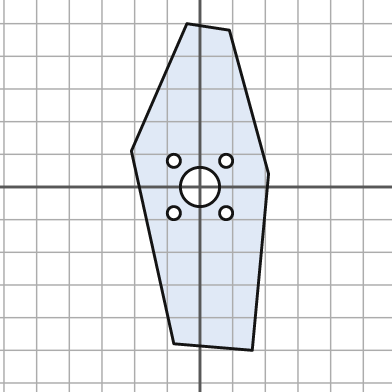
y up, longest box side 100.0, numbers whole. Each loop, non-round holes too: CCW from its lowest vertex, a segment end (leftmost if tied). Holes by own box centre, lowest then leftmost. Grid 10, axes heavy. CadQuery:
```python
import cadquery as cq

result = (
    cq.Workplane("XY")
    .moveTo(16.0, -50.0)
    .lineTo(21.0, 4.0)
    .lineTo(9.0, 48.0)
    .lineTo(-4.0, 50.0)
    .lineTo(-21.0, 11.0)
    .lineTo(-8.0, -48.0)
    .close()
    .moveTo(-8.0, -8.0)
    .circle(2.0)
    .moveTo(8.0, -8.0)
    .circle(2.0)
    .moveTo(0.0, 0.0)
    .circle(6.0)
    .moveTo(-8.0, 8.0)
    .circle(2.0)
    .moveTo(8.0, 8.0)
    .circle(2.0)
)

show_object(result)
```